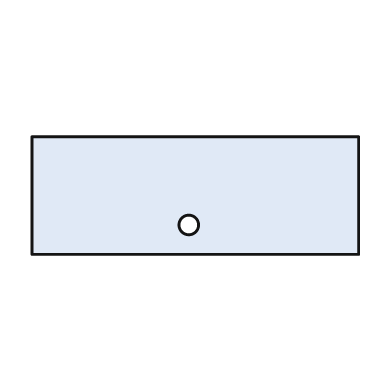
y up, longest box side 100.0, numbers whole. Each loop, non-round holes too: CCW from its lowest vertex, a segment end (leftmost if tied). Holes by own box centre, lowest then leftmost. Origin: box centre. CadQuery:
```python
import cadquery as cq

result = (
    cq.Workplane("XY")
    .moveTo(-50.0, -18.0)
    .lineTo(50.0, -18.0)
    .lineTo(50.0, 18.0)
    .lineTo(-50.0, 18.0)
    .close()
    .moveTo(-2.0, -9.0)
    .circle(3.0)
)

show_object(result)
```